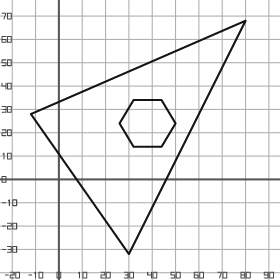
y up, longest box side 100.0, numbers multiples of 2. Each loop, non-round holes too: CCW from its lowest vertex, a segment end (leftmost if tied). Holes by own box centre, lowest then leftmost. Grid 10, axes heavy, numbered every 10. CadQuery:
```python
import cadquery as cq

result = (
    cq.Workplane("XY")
    .moveTo(30.0, -32.0)
    .lineTo(80.0, 68.0)
    .lineTo(-12.0, 28.0)
    .close()
    .moveTo(32.0, 14.0)
    .lineTo(44.0, 14.0)
    .lineTo(50.0, 24.0)
    .lineTo(44.0, 34.0)
    .lineTo(32.0, 34.0)
    .lineTo(26.0, 24.0)
    .close()
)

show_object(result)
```